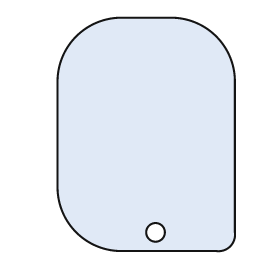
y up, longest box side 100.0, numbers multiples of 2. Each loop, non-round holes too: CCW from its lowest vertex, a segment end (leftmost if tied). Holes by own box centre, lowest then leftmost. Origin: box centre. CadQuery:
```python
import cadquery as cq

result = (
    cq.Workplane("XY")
    .moveTo(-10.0, -50.0)
    .lineTo(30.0, -50.0)
    .threePointArc((36.0, -48.0), (38.0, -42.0))
    .lineTo(38.0, 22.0)
    .threePointArc((30.0, 42.0), (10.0, 50.0))
    .lineTo(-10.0, 50.0)
    .threePointArc((-30.0, 42.0), (-38.0, 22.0))
    .lineTo(-38.0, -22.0)
    .threePointArc((-30.0, -42.0), (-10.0, -50.0))
    .close()
    .moveTo(4.0, -42.0)
    .circle(4.0)
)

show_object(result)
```